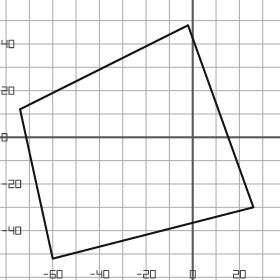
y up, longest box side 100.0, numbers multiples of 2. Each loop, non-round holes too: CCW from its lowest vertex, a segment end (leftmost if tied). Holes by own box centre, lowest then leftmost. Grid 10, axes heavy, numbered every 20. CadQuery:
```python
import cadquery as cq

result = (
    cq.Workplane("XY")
    .moveTo(-60.0, -52.0)
    .lineTo(26.0, -30.0)
    .lineTo(-2.0, 48.0)
    .lineTo(-74.0, 12.0)
    .close()
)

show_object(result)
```